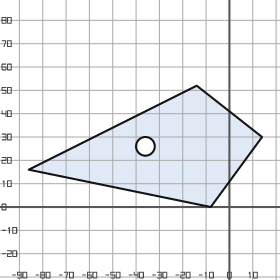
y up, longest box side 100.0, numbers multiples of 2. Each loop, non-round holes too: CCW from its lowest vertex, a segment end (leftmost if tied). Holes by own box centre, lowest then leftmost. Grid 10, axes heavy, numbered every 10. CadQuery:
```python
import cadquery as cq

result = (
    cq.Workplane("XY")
    .moveTo(-8.0, 0.0)
    .lineTo(14.0, 30.0)
    .lineTo(-14.0, 52.0)
    .lineTo(-86.0, 16.0)
    .close()
    .moveTo(-36.0, 26.0)
    .circle(4.0)
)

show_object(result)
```